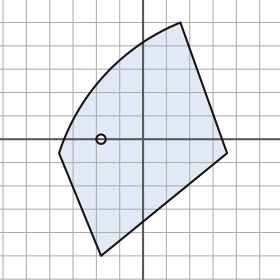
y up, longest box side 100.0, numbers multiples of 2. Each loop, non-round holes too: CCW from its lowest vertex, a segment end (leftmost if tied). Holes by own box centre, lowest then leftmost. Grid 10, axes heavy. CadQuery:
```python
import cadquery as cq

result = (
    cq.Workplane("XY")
    .moveTo(-18.0, -50.0)
    .lineTo(36.0, -6.0)
    .lineTo(16.0, 50.0)
    .threePointArc((-16.0, 28.0), (-36.0, -6.0))
    .close()
    .moveTo(-18.0, 0.0)
    .circle(2.0)
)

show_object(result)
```